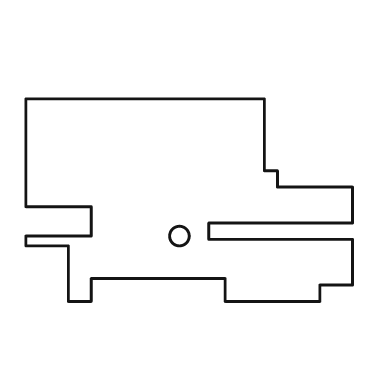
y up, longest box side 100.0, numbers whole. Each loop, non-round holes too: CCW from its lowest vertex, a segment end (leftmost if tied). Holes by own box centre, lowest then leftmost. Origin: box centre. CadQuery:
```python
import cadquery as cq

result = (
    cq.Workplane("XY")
    .moveTo(-37.0, -31.0)
    .lineTo(-30.0, -31.0)
    .lineTo(-30.0, -24.0)
    .lineTo(11.0, -24.0)
    .lineTo(11.0, -31.0)
    .lineTo(40.0, -31.0)
    .lineTo(40.0, -26.0)
    .lineTo(50.0, -26.0)
    .lineTo(50.0, -12.0)
    .lineTo(6.0, -12.0)
    .lineTo(6.0, -7.0)
    .lineTo(50.0, -7.0)
    .lineTo(50.0, 4.0)
    .lineTo(27.0, 4.0)
    .lineTo(27.0, 9.0)
    .lineTo(23.0, 9.0)
    .lineTo(23.0, 31.0)
    .lineTo(-50.0, 31.0)
    .lineTo(-50.0, -2.0)
    .lineTo(-30.0, -2.0)
    .lineTo(-30.0, -11.0)
    .lineTo(-50.0, -11.0)
    .lineTo(-50.0, -14.0)
    .lineTo(-37.0, -14.0)
    .close()
    .moveTo(-3.0, -11.0)
    .circle(3.0)
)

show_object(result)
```